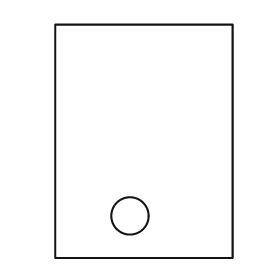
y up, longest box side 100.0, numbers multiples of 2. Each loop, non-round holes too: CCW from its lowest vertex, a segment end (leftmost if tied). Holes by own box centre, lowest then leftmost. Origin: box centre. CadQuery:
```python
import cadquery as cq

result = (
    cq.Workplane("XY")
    .moveTo(-38.0, -50.0)
    .lineTo(38.0, -50.0)
    .lineTo(38.0, 50.0)
    .lineTo(-38.0, 50.0)
    .close()
    .moveTo(-6.0, -32.0)
    .circle(8.0)
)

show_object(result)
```